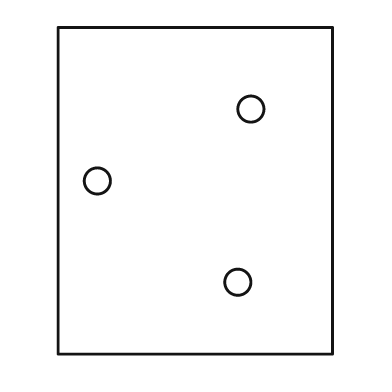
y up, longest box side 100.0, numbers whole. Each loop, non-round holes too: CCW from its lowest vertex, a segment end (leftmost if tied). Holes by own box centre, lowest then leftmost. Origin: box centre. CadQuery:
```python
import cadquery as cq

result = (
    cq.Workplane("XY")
    .moveTo(-42.0, -50.0)
    .lineTo(42.0, -50.0)
    .lineTo(42.0, 50.0)
    .lineTo(-42.0, 50.0)
    .close()
    .moveTo(13.0, -28.0)
    .circle(4.0)
    .moveTo(-30.0, 3.0)
    .circle(4.0)
    .moveTo(17.0, 25.0)
    .circle(4.0)
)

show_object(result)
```